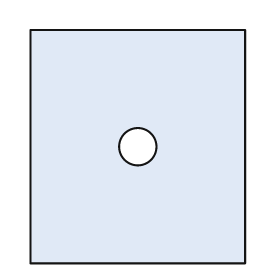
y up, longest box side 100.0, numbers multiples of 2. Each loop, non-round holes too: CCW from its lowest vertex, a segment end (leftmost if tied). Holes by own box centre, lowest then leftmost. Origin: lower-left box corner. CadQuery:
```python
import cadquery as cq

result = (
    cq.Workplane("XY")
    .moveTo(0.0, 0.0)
    .lineTo(92.0, 0.0)
    .lineTo(92.0, 100.0)
    .lineTo(0.0, 100.0)
    .close()
    .moveTo(46.0, 50.0)
    .circle(8.0)
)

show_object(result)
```